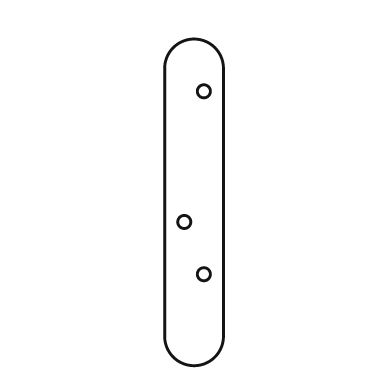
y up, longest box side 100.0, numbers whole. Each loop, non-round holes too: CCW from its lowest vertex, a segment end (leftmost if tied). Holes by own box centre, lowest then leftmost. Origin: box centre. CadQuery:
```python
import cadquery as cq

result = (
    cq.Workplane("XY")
    .moveTo(-9.0, -41.0)
    .threePointArc((0.0, -50.0), (9.0, -41.0))
    .lineTo(9.0, 41.0)
    .threePointArc((0.0, 50.0), (-9.0, 41.0))
    .close()
    .moveTo(3.0, -22.0)
    .circle(2.0)
    .moveTo(-3.0, -6.0)
    .circle(2.0)
    .moveTo(3.0, 34.0)
    .circle(2.0)
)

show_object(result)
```